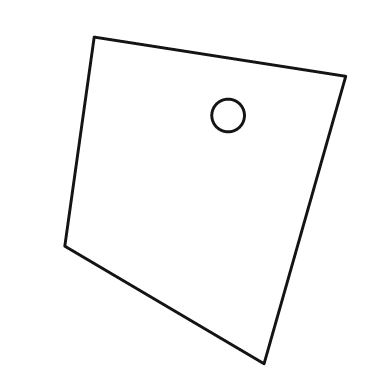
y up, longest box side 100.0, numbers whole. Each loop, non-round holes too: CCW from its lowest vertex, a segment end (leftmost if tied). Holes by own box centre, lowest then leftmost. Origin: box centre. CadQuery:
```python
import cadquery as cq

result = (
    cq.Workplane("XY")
    .moveTo(18.0, -50.0)
    .lineTo(43.0, 38.0)
    .lineTo(-34.0, 50.0)
    .lineTo(-43.0, -14.0)
    .close()
    .moveTo(7.0, 26.0)
    .circle(5.0)
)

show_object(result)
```